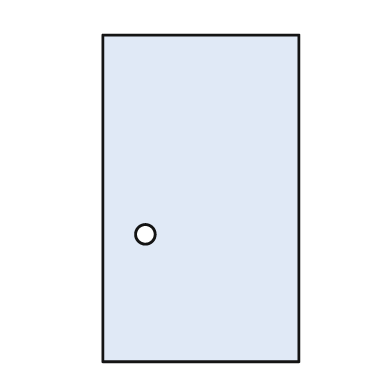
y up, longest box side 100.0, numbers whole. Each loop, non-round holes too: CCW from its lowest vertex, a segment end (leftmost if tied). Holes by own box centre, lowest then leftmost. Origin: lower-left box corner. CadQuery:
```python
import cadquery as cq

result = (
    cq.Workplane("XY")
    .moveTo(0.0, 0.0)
    .lineTo(60.0, 0.0)
    .lineTo(60.0, 100.0)
    .lineTo(0.0, 100.0)
    .close()
    .moveTo(13.0, 39.0)
    .circle(3.0)
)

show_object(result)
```